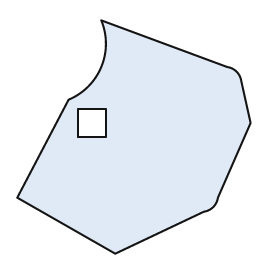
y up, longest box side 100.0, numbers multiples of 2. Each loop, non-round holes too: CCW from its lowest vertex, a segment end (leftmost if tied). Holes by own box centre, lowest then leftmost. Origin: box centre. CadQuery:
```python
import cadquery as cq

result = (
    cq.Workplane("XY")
    .moveTo(-8.0, -50.0)
    .lineTo(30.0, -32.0)
    .threePointArc((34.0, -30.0), (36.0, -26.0))
    .lineTo(50.0, 6.0)
    .lineTo(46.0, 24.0)
    .threePointArc((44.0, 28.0), (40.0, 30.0))
    .lineTo(-14.0, 50.0)
    .threePointArc((-14.0, 30.0), (-28.0, 16.0))
    .lineTo(-50.0, -26.0)
    .close()
    .moveTo(-24.0, 0.0)
    .lineTo(-12.0, 0.0)
    .lineTo(-12.0, 12.0)
    .lineTo(-24.0, 12.0)
    .close()
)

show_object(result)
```